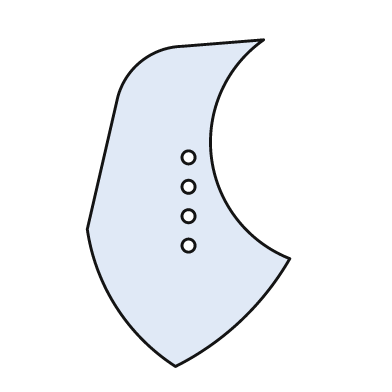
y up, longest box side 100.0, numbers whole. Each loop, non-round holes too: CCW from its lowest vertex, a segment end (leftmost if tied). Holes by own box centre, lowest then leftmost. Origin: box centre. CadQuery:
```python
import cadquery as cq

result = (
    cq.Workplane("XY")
    .moveTo(-4.0, -50.0)
    .threePointArc((16.0, -36.0), (31.0, -17.0))
    .threePointArc((7.0, 14.0), (23.0, 50.0))
    .lineTo(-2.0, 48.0)
    .threePointArc((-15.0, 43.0), (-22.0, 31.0))
    .lineTo(-31.0, -8.0)
    .threePointArc((-22.0, -32.0), (-4.0, -50.0))
    .close()
    .moveTo(0.0, -13.0)
    .circle(2.0)
    .moveTo(0.0, -4.0)
    .circle(2.0)
    .moveTo(0.0, 5.0)
    .circle(2.0)
    .moveTo(0.0, 14.0)
    .circle(2.0)
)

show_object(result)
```